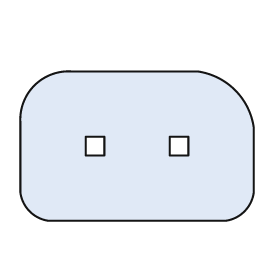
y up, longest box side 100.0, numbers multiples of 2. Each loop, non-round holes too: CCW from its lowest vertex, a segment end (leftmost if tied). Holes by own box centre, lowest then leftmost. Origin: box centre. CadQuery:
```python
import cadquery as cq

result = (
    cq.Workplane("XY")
    .moveTo(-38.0, -32.0)
    .lineTo(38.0, -32.0)
    .threePointArc((46.0, -28.0), (50.0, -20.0))
    .lineTo(50.0, 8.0)
    .threePointArc((42.0, 24.0), (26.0, 32.0))
    .lineTo(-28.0, 32.0)
    .threePointArc((-44.0, 26.0), (-50.0, 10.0))
    .lineTo(-50.0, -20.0)
    .threePointArc((-46.0, -28.0), (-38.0, -32.0))
    .close()
    .moveTo(-22.0, -4.0)
    .lineTo(-14.0, -4.0)
    .lineTo(-14.0, 4.0)
    .lineTo(-22.0, 4.0)
    .close()
    .moveTo(14.0, -4.0)
    .lineTo(22.0, -4.0)
    .lineTo(22.0, 4.0)
    .lineTo(14.0, 4.0)
    .close()
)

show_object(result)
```